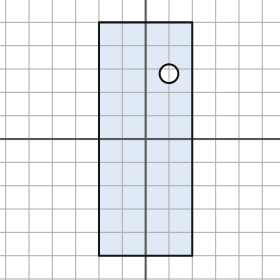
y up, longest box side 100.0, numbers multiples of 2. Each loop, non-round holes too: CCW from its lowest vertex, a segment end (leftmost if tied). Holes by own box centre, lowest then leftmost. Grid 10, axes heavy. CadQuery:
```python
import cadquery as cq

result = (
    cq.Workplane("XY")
    .moveTo(-20.0, -50.0)
    .lineTo(20.0, -50.0)
    .lineTo(20.0, 50.0)
    .lineTo(-20.0, 50.0)
    .close()
    .moveTo(10.0, 28.0)
    .circle(4.0)
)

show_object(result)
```